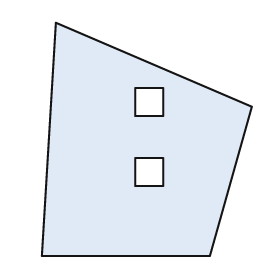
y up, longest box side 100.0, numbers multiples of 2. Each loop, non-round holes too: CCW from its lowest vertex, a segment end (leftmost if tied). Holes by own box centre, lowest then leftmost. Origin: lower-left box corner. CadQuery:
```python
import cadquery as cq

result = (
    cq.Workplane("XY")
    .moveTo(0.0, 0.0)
    .lineTo(72.0, 0.0)
    .lineTo(90.0, 64.0)
    .lineTo(6.0, 100.0)
    .close()
    .moveTo(40.0, 30.0)
    .lineTo(52.0, 30.0)
    .lineTo(52.0, 42.0)
    .lineTo(40.0, 42.0)
    .close()
    .moveTo(40.0, 60.0)
    .lineTo(52.0, 60.0)
    .lineTo(52.0, 72.0)
    .lineTo(40.0, 72.0)
    .close()
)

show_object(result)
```